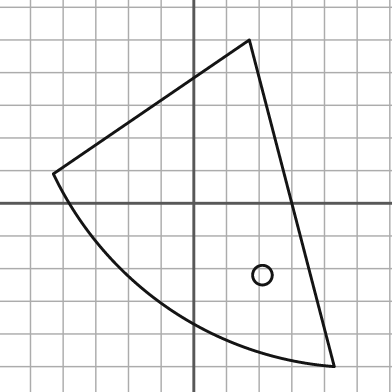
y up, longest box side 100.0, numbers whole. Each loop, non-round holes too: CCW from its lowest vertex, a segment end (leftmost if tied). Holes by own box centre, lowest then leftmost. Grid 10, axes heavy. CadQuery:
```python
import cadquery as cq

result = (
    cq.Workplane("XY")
    .moveTo(43.0, -50.0)
    .lineTo(17.0, 50.0)
    .lineTo(-43.0, 9.0)
    .threePointArc((-8.0, -32.0), (43.0, -50.0))
    .close()
    .moveTo(21.0, -22.0)
    .circle(3.0)
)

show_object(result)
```